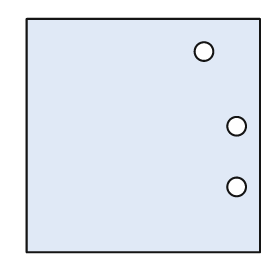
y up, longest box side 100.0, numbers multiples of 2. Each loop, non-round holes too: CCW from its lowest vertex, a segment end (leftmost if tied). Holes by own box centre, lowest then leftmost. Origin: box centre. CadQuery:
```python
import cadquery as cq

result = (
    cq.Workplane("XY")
    .moveTo(-50.0, -50.0)
    .lineTo(50.0, -50.0)
    .lineTo(50.0, 50.0)
    .lineTo(-50.0, 50.0)
    .close()
    .moveTo(40.0, -22.0)
    .circle(4.0)
    .moveTo(40.0, 4.0)
    .circle(4.0)
    .moveTo(26.0, 36.0)
    .circle(4.0)
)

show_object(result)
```